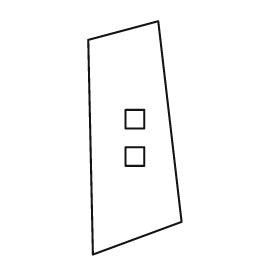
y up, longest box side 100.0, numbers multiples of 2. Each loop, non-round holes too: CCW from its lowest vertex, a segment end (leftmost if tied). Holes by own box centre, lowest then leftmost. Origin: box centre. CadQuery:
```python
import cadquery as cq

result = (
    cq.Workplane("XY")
    .moveTo(-18.0, -50.0)
    .lineTo(20.0, -36.0)
    .lineTo(10.0, 50.0)
    .lineTo(-20.0, 42.0)
    .close()
    .moveTo(-4.0, -12.0)
    .lineTo(4.0, -12.0)
    .lineTo(4.0, -4.0)
    .lineTo(-4.0, -4.0)
    .close()
    .moveTo(-4.0, 4.0)
    .lineTo(4.0, 4.0)
    .lineTo(4.0, 12.0)
    .lineTo(-4.0, 12.0)
    .close()
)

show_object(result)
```